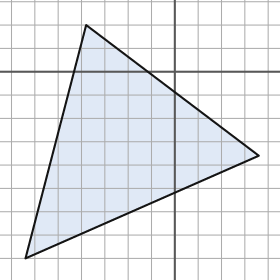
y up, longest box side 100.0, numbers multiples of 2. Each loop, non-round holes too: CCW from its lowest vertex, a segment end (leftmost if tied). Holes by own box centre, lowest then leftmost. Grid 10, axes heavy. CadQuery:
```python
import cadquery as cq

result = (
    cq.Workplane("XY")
    .moveTo(-64.0, -80.0)
    .lineTo(36.0, -36.0)
    .lineTo(-38.0, 20.0)
    .close()
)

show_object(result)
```